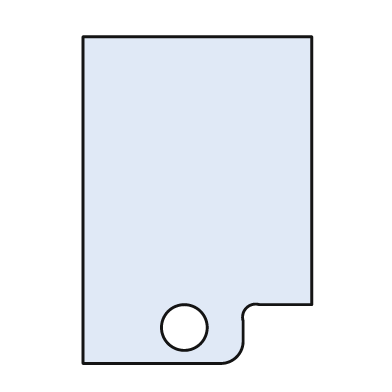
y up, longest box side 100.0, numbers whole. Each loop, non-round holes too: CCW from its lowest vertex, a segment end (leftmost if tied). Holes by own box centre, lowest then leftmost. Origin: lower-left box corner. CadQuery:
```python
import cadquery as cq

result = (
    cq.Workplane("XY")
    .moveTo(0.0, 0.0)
    .lineTo(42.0, 0.0)
    .threePointArc((47.0, 2.0), (49.0, 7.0))
    .lineTo(49.0, 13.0)
    .threePointArc((50.0, 17.0), (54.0, 18.0))
    .lineTo(70.0, 18.0)
    .lineTo(70.0, 100.0)
    .lineTo(0.0, 100.0)
    .close()
    .moveTo(31.0, 11.0)
    .circle(7.0)
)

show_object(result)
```